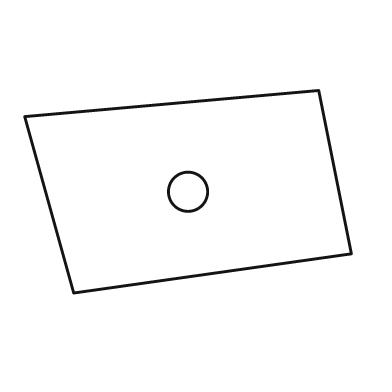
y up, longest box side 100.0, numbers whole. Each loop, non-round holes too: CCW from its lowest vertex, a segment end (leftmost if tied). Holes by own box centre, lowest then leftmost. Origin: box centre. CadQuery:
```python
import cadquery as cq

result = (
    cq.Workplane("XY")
    .moveTo(-35.0, -31.0)
    .lineTo(50.0, -19.0)
    .lineTo(40.0, 31.0)
    .lineTo(-50.0, 23.0)
    .close()
    .moveTo(0.0, 0.0)
    .circle(6.0)
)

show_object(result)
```